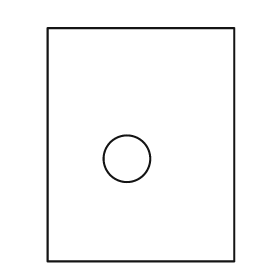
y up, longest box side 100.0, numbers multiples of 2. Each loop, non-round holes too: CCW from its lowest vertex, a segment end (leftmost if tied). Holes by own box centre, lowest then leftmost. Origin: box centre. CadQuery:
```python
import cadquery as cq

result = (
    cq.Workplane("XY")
    .moveTo(-40.0, -50.0)
    .lineTo(40.0, -50.0)
    .lineTo(40.0, 50.0)
    .lineTo(-40.0, 50.0)
    .close()
    .moveTo(-6.0, -6.0)
    .circle(10.0)
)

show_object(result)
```